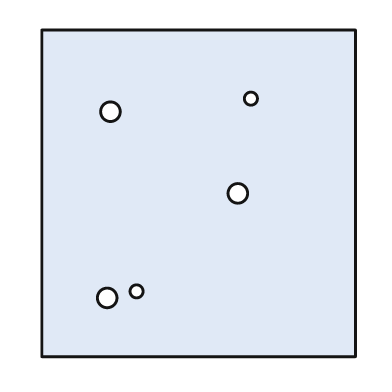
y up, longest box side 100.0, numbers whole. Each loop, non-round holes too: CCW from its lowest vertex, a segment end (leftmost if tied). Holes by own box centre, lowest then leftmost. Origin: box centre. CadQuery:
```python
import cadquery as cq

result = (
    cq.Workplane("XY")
    .moveTo(-48.0, -50.0)
    .lineTo(48.0, -50.0)
    .lineTo(48.0, 50.0)
    .lineTo(-48.0, 50.0)
    .close()
    .moveTo(-28.0, -32.0)
    .circle(3.0)
    .moveTo(-19.0, -30.0)
    .circle(2.0)
    .moveTo(12.0, 0.0)
    .circle(3.0)
    .moveTo(-27.0, 25.0)
    .circle(3.0)
    .moveTo(16.0, 29.0)
    .circle(2.0)
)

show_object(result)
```